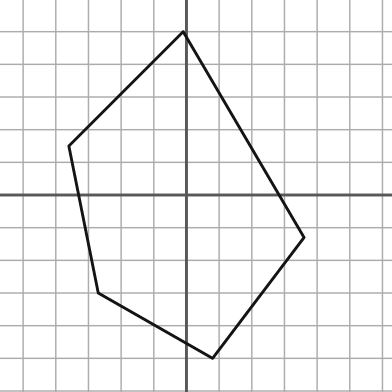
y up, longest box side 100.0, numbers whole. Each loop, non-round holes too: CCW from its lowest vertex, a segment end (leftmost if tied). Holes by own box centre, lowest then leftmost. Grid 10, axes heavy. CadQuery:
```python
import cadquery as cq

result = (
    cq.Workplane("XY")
    .moveTo(8.0, -50.0)
    .lineTo(36.0, -13.0)
    .lineTo(-1.0, 50.0)
    .lineTo(-36.0, 15.0)
    .lineTo(-27.0, -30.0)
    .close()
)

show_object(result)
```